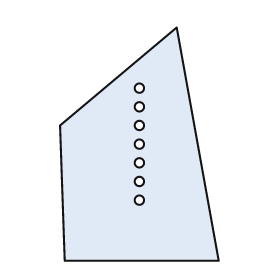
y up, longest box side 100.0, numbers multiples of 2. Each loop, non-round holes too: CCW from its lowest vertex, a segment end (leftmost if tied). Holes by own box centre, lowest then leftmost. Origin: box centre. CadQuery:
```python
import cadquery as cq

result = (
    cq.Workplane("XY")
    .moveTo(-32.0, -50.0)
    .lineTo(34.0, -50.0)
    .lineTo(16.0, 50.0)
    .lineTo(-34.0, 8.0)
    .close()
    .moveTo(0.0, -24.0)
    .circle(2.0)
    .moveTo(0.0, -16.0)
    .circle(2.0)
    .moveTo(0.0, -8.0)
    .circle(2.0)
    .moveTo(0.0, 0.0)
    .circle(2.0)
    .moveTo(0.0, 8.0)
    .circle(2.0)
    .moveTo(0.0, 16.0)
    .circle(2.0)
    .moveTo(0.0, 24.0)
    .circle(2.0)
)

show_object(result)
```